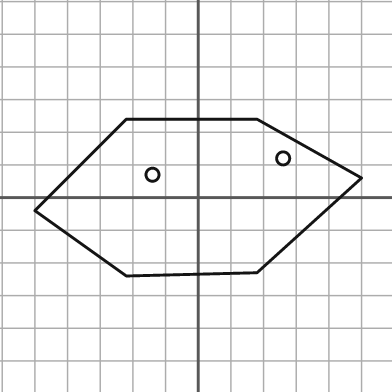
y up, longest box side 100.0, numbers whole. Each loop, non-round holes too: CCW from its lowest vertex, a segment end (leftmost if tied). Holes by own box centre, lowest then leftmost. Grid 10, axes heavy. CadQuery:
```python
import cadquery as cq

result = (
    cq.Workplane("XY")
    .moveTo(-22.0, -24.0)
    .lineTo(18.0, -23.0)
    .lineTo(50.0, 6.0)
    .lineTo(18.0, 24.0)
    .lineTo(-22.0, 24.0)
    .lineTo(-50.0, -4.0)
    .close()
    .moveTo(-14.0, 7.0)
    .circle(2.0)
    .moveTo(26.0, 12.0)
    .circle(2.0)
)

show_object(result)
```